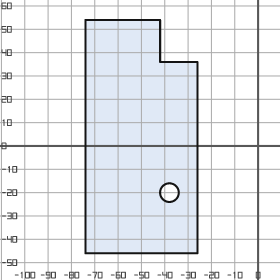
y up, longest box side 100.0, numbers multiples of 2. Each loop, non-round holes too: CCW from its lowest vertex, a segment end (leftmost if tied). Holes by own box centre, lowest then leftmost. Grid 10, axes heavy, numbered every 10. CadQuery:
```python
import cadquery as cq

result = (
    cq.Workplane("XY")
    .moveTo(-74.0, -46.0)
    .lineTo(-26.0, -46.0)
    .lineTo(-26.0, 36.0)
    .lineTo(-42.0, 36.0)
    .lineTo(-42.0, 54.0)
    .lineTo(-74.0, 54.0)
    .close()
    .moveTo(-38.0, -20.0)
    .circle(4.0)
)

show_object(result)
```